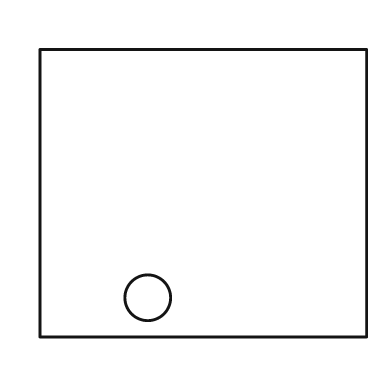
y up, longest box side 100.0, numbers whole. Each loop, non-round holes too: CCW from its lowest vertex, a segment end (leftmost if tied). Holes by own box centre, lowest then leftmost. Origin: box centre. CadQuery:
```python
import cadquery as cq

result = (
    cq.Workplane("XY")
    .moveTo(-50.0, -44.0)
    .lineTo(50.0, -44.0)
    .lineTo(50.0, 44.0)
    .lineTo(-50.0, 44.0)
    .close()
    .moveTo(-17.0, -32.0)
    .circle(7.0)
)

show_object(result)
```